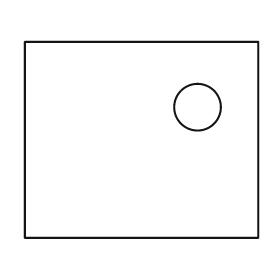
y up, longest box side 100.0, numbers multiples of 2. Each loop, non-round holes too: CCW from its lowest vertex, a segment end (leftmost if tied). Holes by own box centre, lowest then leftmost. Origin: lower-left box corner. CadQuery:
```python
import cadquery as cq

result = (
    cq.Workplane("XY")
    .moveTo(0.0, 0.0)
    .lineTo(100.0, 0.0)
    .lineTo(100.0, 84.0)
    .lineTo(0.0, 84.0)
    .close()
    .moveTo(74.0, 56.0)
    .circle(10.0)
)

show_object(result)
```